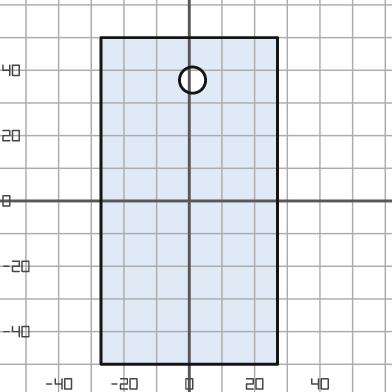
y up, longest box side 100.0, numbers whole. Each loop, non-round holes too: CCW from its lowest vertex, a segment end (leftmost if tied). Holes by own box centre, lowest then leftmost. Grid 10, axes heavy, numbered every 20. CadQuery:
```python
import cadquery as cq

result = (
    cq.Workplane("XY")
    .moveTo(-27.0, -50.0)
    .lineTo(27.0, -50.0)
    .lineTo(27.0, 50.0)
    .lineTo(-27.0, 50.0)
    .close()
    .moveTo(1.0, 37.0)
    .circle(4.0)
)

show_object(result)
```